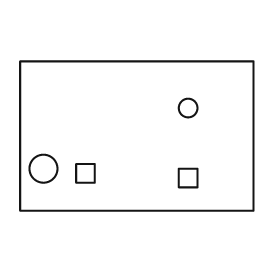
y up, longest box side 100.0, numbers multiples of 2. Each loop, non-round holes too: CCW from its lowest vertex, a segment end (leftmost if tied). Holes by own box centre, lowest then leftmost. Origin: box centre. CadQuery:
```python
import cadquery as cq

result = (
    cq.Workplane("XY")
    .moveTo(-50.0, -32.0)
    .lineTo(50.0, -32.0)
    .lineTo(50.0, 32.0)
    .lineTo(-50.0, 32.0)
    .close()
    .moveTo(18.0, -22.0)
    .lineTo(26.0, -22.0)
    .lineTo(26.0, -14.0)
    .lineTo(18.0, -14.0)
    .close()
    .moveTo(-26.0, -20.0)
    .lineTo(-18.0, -20.0)
    .lineTo(-18.0, -12.0)
    .lineTo(-26.0, -12.0)
    .close()
    .moveTo(-40.0, -14.0)
    .circle(6.0)
    .moveTo(22.0, 12.0)
    .circle(4.0)
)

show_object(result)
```